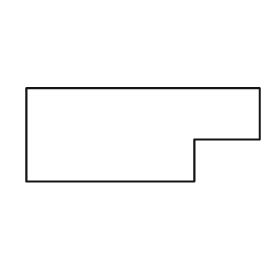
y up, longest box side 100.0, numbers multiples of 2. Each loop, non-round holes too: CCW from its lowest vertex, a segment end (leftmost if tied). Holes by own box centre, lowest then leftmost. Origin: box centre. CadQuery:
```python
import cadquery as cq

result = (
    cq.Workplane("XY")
    .moveTo(-50.0, -20.0)
    .lineTo(22.0, -20.0)
    .lineTo(22.0, -2.0)
    .lineTo(50.0, -2.0)
    .lineTo(50.0, 20.0)
    .lineTo(-50.0, 20.0)
    .close()
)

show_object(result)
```